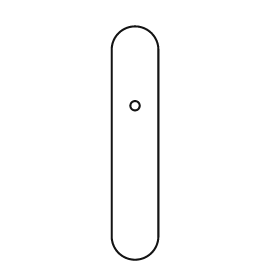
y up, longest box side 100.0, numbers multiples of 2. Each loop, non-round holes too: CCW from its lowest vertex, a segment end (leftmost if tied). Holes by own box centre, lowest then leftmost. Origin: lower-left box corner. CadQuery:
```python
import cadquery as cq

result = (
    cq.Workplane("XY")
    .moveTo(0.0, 10.0)
    .threePointArc((10.0, 0.0), (20.0, 10.0))
    .lineTo(20.0, 90.0)
    .threePointArc((10.0, 100.0), (0.0, 90.0))
    .close()
    .moveTo(10.0, 66.0)
    .circle(2.0)
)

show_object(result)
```